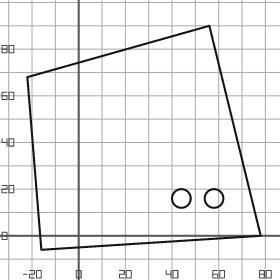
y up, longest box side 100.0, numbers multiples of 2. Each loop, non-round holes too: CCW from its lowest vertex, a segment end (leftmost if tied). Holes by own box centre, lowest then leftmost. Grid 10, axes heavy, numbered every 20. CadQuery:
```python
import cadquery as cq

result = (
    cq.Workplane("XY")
    .moveTo(-16.0, -6.0)
    .lineTo(78.0, 0.0)
    .lineTo(56.0, 90.0)
    .lineTo(-22.0, 68.0)
    .close()
    .moveTo(44.0, 16.0)
    .circle(4.0)
    .moveTo(58.0, 16.0)
    .circle(4.0)
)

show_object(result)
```